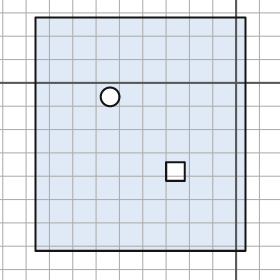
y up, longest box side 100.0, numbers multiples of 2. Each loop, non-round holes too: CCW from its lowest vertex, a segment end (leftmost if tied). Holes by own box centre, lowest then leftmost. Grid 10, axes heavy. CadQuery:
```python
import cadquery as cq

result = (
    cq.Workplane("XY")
    .moveTo(-86.0, -72.0)
    .lineTo(4.0, -72.0)
    .lineTo(4.0, 28.0)
    .lineTo(-86.0, 28.0)
    .close()
    .moveTo(-30.0, -42.0)
    .lineTo(-22.0, -42.0)
    .lineTo(-22.0, -34.0)
    .lineTo(-30.0, -34.0)
    .close()
    .moveTo(-54.0, -6.0)
    .circle(4.0)
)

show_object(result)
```